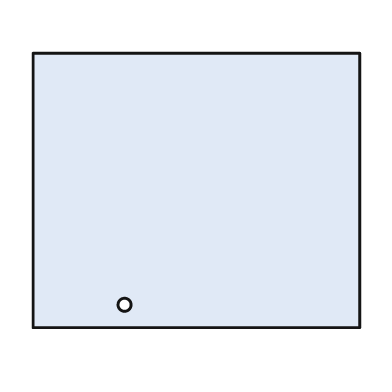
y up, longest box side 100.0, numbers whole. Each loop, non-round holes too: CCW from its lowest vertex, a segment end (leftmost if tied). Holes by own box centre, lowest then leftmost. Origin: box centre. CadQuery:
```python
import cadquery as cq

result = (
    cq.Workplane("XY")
    .moveTo(-50.0, -42.0)
    .lineTo(50.0, -42.0)
    .lineTo(50.0, 42.0)
    .lineTo(-50.0, 42.0)
    .close()
    .moveTo(-22.0, -35.0)
    .circle(2.0)
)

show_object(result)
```